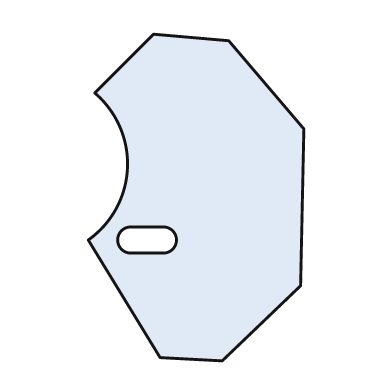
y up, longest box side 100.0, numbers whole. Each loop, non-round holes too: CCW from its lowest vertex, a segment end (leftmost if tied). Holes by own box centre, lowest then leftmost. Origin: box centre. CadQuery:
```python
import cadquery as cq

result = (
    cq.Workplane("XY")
    .moveTo(8.0, -50.0)
    .lineTo(32.0, -27.0)
    .lineTo(33.0, 21.0)
    .lineTo(10.0, 48.0)
    .lineTo(-13.0, 50.0)
    .lineTo(-31.0, 32.0)
    .threePointArc((-21.0, 9.0), (-33.0, -13.0))
    .lineTo(-11.0, -49.0)
    .close()
    .moveTo(-20.0, -17.0)
    .lineTo(-10.0, -17.0)
    .threePointArc((-6.0, -13.0), (-10.0, -9.0))
    .lineTo(-20.0, -9.0)
    .threePointArc((-24.0, -13.0), (-20.0, -17.0))
    .close()
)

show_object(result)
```